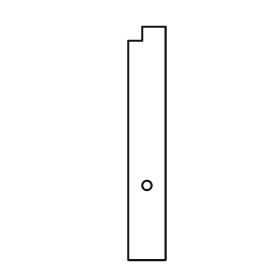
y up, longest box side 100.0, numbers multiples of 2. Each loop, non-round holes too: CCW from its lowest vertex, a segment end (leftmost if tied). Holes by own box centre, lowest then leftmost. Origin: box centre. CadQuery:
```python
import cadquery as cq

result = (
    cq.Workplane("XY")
    .moveTo(-8.0, -50.0)
    .lineTo(8.0, -50.0)
    .lineTo(8.0, 50.0)
    .lineTo(-2.0, 50.0)
    .lineTo(-2.0, 44.0)
    .lineTo(-8.0, 44.0)
    .close()
    .moveTo(0.0, -18.0)
    .circle(2.0)
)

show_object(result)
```